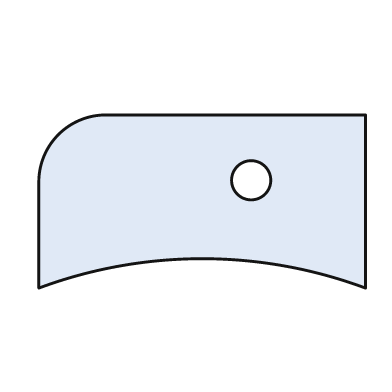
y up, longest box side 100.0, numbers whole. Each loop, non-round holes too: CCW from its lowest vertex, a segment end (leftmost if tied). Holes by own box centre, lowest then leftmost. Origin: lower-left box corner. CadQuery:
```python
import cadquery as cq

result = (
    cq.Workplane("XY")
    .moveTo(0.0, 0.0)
    .threePointArc((50.0, 9.0), (100.0, 0.0))
    .lineTo(100.0, 53.0)
    .lineTo(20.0, 53.0)
    .threePointArc((6.0, 47.0), (0.0, 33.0))
    .close()
    .moveTo(65.0, 33.0)
    .circle(6.0)
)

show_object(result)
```